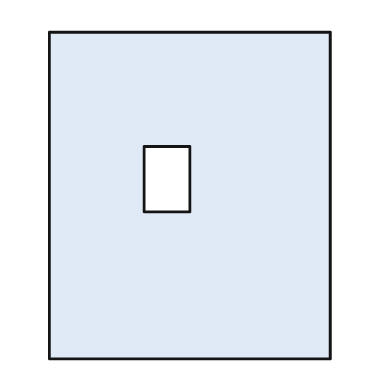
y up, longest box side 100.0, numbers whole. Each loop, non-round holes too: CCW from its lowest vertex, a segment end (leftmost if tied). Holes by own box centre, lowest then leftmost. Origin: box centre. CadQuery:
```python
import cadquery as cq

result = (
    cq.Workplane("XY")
    .moveTo(-43.0, -50.0)
    .lineTo(43.0, -50.0)
    .lineTo(43.0, 50.0)
    .lineTo(-43.0, 50.0)
    .close()
    .moveTo(-14.0, -5.0)
    .lineTo(0.0, -5.0)
    .lineTo(0.0, 15.0)
    .lineTo(-14.0, 15.0)
    .close()
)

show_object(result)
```